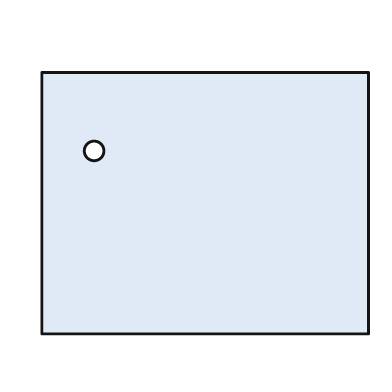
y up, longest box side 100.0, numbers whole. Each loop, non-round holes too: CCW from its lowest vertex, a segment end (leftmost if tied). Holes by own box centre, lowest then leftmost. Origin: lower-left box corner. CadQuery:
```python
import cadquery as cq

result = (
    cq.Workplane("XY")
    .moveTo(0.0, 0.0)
    .lineTo(100.0, 0.0)
    .lineTo(100.0, 80.0)
    .lineTo(0.0, 80.0)
    .close()
    .moveTo(16.0, 56.0)
    .circle(3.0)
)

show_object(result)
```